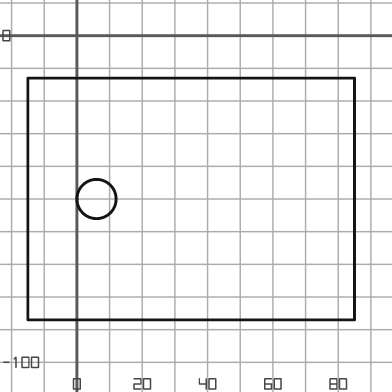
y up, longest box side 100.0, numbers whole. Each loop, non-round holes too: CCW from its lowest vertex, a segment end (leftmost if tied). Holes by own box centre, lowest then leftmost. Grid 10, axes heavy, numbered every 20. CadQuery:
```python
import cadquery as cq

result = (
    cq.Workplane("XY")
    .moveTo(-15.0, -87.0)
    .lineTo(85.0, -87.0)
    .lineTo(85.0, -13.0)
    .lineTo(-15.0, -13.0)
    .close()
    .moveTo(6.0, -50.0)
    .circle(6.0)
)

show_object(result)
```